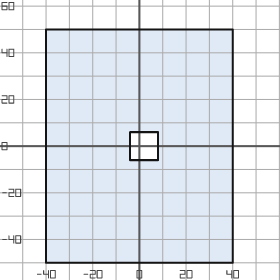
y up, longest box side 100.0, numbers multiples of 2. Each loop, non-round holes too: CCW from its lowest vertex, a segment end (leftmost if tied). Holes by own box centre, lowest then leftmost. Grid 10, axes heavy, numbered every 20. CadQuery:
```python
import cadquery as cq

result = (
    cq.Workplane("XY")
    .moveTo(-40.0, -50.0)
    .lineTo(40.0, -50.0)
    .lineTo(40.0, 50.0)
    .lineTo(-40.0, 50.0)
    .close()
    .moveTo(-4.0, -6.0)
    .lineTo(8.0, -6.0)
    .lineTo(8.0, 6.0)
    .lineTo(-4.0, 6.0)
    .close()
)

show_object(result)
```